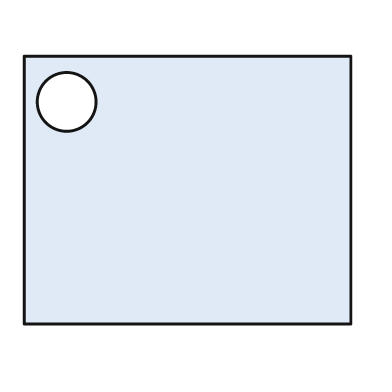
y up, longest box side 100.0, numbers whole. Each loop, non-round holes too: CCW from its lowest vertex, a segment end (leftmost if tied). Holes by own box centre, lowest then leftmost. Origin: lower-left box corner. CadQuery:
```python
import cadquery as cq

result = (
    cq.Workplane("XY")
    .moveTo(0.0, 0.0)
    .lineTo(100.0, 0.0)
    .lineTo(100.0, 82.0)
    .lineTo(0.0, 82.0)
    .close()
    .moveTo(13.0, 68.0)
    .circle(9.0)
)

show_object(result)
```